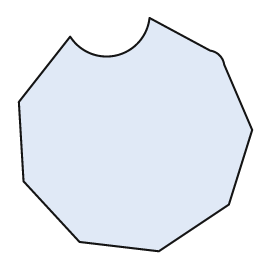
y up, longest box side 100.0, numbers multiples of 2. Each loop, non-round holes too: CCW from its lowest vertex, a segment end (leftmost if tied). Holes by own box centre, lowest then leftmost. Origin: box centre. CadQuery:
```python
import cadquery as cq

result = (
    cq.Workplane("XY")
    .moveTo(10.0, -50.0)
    .lineTo(40.0, -30.0)
    .lineTo(50.0, 2.0)
    .lineTo(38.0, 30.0)
    .threePointArc((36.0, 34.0), (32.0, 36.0))
    .lineTo(6.0, 50.0)
    .threePointArc((-8.0, 34.0), (-28.0, 42.0))
    .lineTo(-50.0, 14.0)
    .lineTo(-48.0, -20.0)
    .lineTo(-24.0, -46.0)
    .close()
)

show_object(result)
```